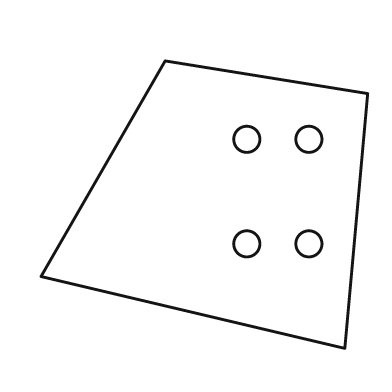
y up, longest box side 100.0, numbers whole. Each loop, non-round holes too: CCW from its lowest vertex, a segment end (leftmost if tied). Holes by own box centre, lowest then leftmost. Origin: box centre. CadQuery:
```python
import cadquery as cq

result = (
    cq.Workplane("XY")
    .moveTo(43.0, -44.0)
    .lineTo(50.0, 34.0)
    .lineTo(-12.0, 44.0)
    .lineTo(-50.0, -22.0)
    .close()
    .moveTo(13.0, -12.0)
    .circle(4.0)
    .moveTo(32.0, -12.0)
    .circle(4.0)
    .moveTo(13.0, 20.0)
    .circle(4.0)
    .moveTo(32.0, 20.0)
    .circle(4.0)
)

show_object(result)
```